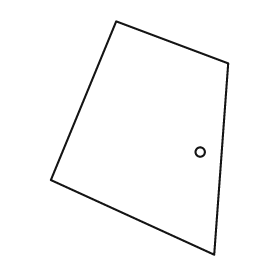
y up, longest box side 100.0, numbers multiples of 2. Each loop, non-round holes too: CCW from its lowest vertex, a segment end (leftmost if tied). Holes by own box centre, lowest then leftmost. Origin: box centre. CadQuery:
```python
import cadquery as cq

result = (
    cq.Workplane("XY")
    .moveTo(32.0, -50.0)
    .lineTo(38.0, 32.0)
    .lineTo(-10.0, 50.0)
    .lineTo(-38.0, -18.0)
    .close()
    .moveTo(26.0, -6.0)
    .circle(2.0)
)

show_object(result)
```